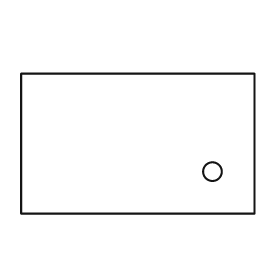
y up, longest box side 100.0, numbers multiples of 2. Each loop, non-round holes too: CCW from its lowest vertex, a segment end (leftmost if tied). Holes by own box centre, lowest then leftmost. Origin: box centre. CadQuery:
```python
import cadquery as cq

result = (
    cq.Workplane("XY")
    .moveTo(-50.0, -30.0)
    .lineTo(50.0, -30.0)
    .lineTo(50.0, 30.0)
    .lineTo(-50.0, 30.0)
    .close()
    .moveTo(32.0, -12.0)
    .circle(4.0)
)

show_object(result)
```